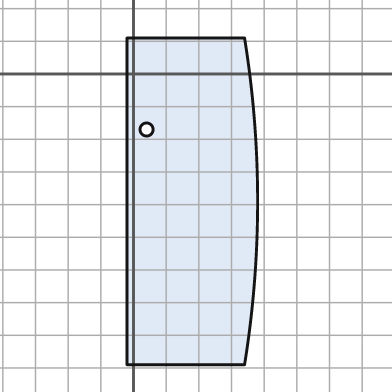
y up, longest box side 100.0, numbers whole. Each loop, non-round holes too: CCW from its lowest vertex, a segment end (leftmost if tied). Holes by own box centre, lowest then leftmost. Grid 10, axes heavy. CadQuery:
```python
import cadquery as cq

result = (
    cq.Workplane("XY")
    .moveTo(-2.0, -89.0)
    .lineTo(34.0, -89.0)
    .threePointArc((38.0, -39.0), (34.0, 11.0))
    .lineTo(-2.0, 11.0)
    .close()
    .moveTo(4.0, -17.0)
    .circle(2.0)
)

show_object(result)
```